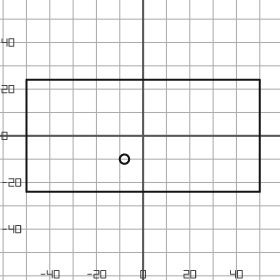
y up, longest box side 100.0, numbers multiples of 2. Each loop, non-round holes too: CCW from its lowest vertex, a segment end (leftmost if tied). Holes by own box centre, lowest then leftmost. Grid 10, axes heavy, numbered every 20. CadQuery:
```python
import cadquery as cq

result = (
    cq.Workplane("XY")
    .moveTo(-50.0, -24.0)
    .lineTo(50.0, -24.0)
    .lineTo(50.0, 24.0)
    .lineTo(-50.0, 24.0)
    .close()
    .moveTo(-8.0, -10.0)
    .circle(2.0)
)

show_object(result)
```